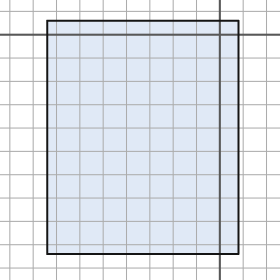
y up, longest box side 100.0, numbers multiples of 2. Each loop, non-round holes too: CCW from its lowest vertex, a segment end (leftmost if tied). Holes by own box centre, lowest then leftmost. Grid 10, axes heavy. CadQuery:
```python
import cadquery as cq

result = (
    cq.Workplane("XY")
    .moveTo(-74.0, -94.0)
    .lineTo(8.0, -94.0)
    .lineTo(8.0, 6.0)
    .lineTo(-74.0, 6.0)
    .close()
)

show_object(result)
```